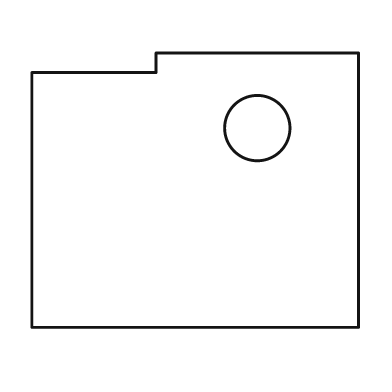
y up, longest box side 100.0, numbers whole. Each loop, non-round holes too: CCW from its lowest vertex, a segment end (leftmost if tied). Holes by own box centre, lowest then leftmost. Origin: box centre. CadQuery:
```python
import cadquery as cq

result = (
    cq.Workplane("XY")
    .moveTo(-50.0, -42.0)
    .lineTo(50.0, -42.0)
    .lineTo(50.0, 42.0)
    .lineTo(-12.0, 42.0)
    .lineTo(-12.0, 36.0)
    .lineTo(-50.0, 36.0)
    .close()
    .moveTo(19.0, 19.0)
    .circle(10.0)
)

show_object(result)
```